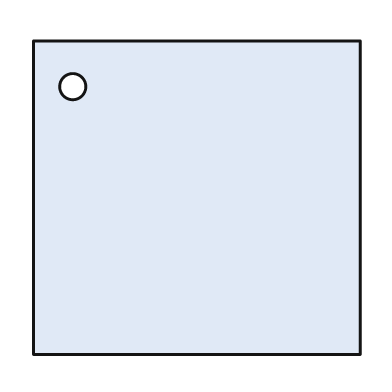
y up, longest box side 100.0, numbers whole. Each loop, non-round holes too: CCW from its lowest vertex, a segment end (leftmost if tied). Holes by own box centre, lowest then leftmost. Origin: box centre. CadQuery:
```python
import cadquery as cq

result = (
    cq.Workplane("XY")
    .moveTo(-50.0, -48.0)
    .lineTo(50.0, -48.0)
    .lineTo(50.0, 48.0)
    .lineTo(-50.0, 48.0)
    .close()
    .moveTo(-38.0, 34.0)
    .circle(4.0)
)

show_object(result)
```